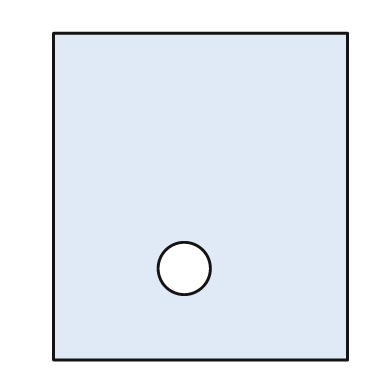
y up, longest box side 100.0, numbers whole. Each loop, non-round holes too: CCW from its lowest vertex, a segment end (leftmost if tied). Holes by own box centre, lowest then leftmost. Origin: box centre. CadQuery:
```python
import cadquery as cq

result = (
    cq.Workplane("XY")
    .moveTo(-45.0, -50.0)
    .lineTo(45.0, -50.0)
    .lineTo(45.0, 50.0)
    .lineTo(-45.0, 50.0)
    .close()
    .moveTo(-5.0, -22.0)
    .circle(8.0)
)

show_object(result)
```